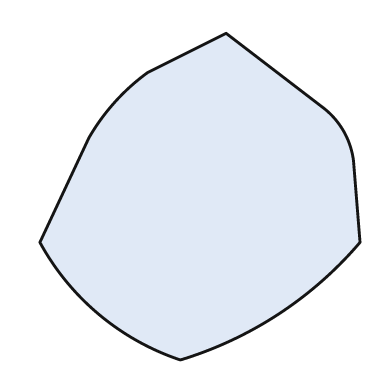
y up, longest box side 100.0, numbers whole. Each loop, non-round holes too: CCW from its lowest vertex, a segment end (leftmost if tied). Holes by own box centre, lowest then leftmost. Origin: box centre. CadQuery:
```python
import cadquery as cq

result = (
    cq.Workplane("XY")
    .moveTo(-6.0, -50.0)
    .threePointArc((24.0, -36.0), (49.0, -14.0))
    .lineTo(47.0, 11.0)
    .threePointArc((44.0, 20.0), (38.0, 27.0))
    .lineTo(8.0, 50.0)
    .lineTo(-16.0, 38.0)
    .threePointArc((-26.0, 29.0), (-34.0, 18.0))
    .lineTo(-49.0, -14.0)
    .threePointArc((-31.0, -36.0), (-6.0, -50.0))
    .close()
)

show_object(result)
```